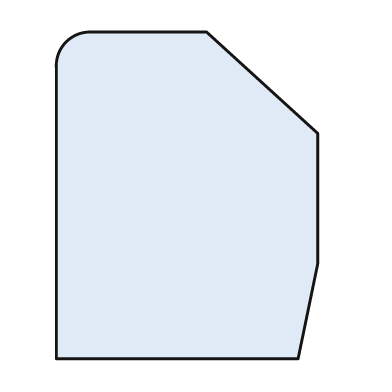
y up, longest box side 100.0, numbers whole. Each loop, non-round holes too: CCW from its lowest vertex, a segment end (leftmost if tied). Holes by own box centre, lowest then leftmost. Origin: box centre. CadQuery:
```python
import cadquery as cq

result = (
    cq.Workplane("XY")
    .moveTo(-40.0, -50.0)
    .lineTo(34.0, -50.0)
    .lineTo(40.0, -21.0)
    .lineTo(40.0, 19.0)
    .lineTo(6.0, 50.0)
    .lineTo(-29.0, 50.0)
    .threePointArc((-37.0, 47.0), (-40.0, 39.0))
    .close()
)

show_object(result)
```